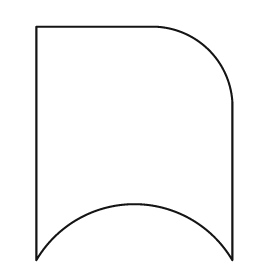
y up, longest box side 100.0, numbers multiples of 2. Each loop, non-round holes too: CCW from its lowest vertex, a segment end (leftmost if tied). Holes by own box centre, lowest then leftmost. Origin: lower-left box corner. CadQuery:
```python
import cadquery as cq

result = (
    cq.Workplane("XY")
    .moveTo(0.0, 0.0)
    .threePointArc((42.0, 24.0), (84.0, 0.0))
    .lineTo(84.0, 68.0)
    .threePointArc((74.0, 90.0), (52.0, 100.0))
    .lineTo(0.0, 100.0)
    .close()
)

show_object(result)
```